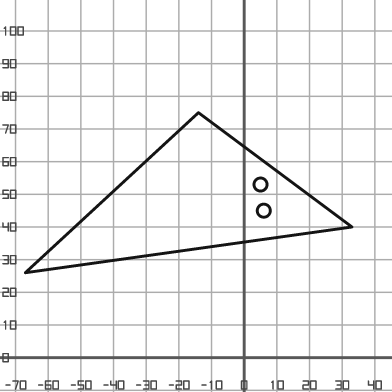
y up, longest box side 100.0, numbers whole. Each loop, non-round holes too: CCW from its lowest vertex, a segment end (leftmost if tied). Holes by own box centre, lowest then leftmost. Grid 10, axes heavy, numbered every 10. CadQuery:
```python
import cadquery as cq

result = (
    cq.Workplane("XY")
    .moveTo(-67.0, 26.0)
    .lineTo(33.0, 40.0)
    .lineTo(-14.0, 75.0)
    .close()
    .moveTo(6.0, 45.0)
    .circle(2.0)
    .moveTo(5.0, 53.0)
    .circle(2.0)
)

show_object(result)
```